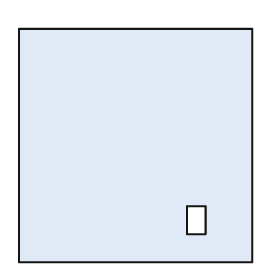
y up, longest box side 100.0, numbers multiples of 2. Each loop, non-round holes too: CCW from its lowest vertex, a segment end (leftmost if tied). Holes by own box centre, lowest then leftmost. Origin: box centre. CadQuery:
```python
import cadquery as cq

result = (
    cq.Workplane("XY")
    .moveTo(-50.0, -50.0)
    .lineTo(50.0, -50.0)
    .lineTo(50.0, 50.0)
    .lineTo(-50.0, 50.0)
    .close()
    .moveTo(22.0, -38.0)
    .lineTo(30.0, -38.0)
    .lineTo(30.0, -26.0)
    .lineTo(22.0, -26.0)
    .close()
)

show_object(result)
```